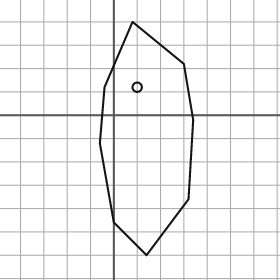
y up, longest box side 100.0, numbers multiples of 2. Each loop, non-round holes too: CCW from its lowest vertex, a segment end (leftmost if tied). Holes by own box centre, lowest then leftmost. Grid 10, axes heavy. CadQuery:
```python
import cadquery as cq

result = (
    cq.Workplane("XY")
    .moveTo(14.0, -60.0)
    .lineTo(32.0, -36.0)
    .lineTo(34.0, -2.0)
    .lineTo(30.0, 22.0)
    .lineTo(8.0, 40.0)
    .lineTo(-4.0, 12.0)
    .lineTo(-6.0, -12.0)
    .lineTo(0.0, -46.0)
    .close()
    .moveTo(10.0, 12.0)
    .circle(2.0)
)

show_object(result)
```